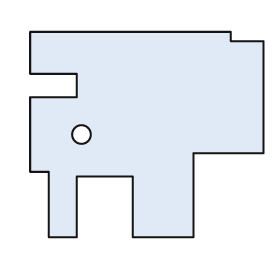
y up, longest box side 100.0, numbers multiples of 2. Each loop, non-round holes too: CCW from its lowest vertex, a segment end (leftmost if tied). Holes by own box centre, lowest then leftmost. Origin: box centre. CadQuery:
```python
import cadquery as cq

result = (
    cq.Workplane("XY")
    .moveTo(-42.0, -44.0)
    .lineTo(-30.0, -44.0)
    .lineTo(-30.0, -18.0)
    .lineTo(-6.0, -18.0)
    .lineTo(-6.0, -44.0)
    .lineTo(20.0, -44.0)
    .lineTo(20.0, -8.0)
    .lineTo(50.0, -8.0)
    .lineTo(50.0, 40.0)
    .lineTo(36.0, 40.0)
    .lineTo(36.0, 44.0)
    .lineTo(-50.0, 44.0)
    .lineTo(-50.0, 26.0)
    .lineTo(-30.0, 26.0)
    .lineTo(-30.0, 16.0)
    .lineTo(-50.0, 16.0)
    .lineTo(-50.0, -16.0)
    .lineTo(-42.0, -16.0)
    .close()
    .moveTo(-28.0, 0.0)
    .circle(4.0)
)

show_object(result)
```